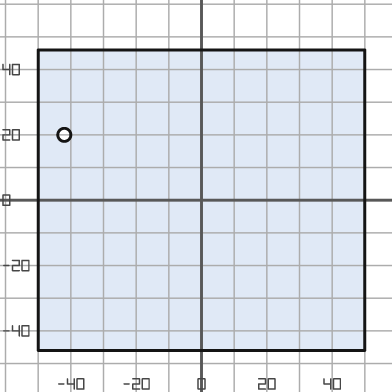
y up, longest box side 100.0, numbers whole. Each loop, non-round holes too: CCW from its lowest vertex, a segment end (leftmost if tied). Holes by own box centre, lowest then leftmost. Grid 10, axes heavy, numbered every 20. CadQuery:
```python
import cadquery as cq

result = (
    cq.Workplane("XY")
    .moveTo(-50.0, -46.0)
    .lineTo(50.0, -46.0)
    .lineTo(50.0, 46.0)
    .lineTo(-50.0, 46.0)
    .close()
    .moveTo(-42.0, 20.0)
    .circle(2.0)
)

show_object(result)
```